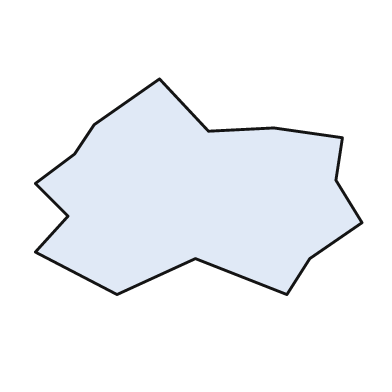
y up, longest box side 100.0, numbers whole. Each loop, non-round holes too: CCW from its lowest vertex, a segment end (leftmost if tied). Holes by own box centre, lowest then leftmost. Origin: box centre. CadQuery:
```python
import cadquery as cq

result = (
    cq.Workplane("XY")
    .moveTo(-25.0, -33.0)
    .lineTo(-1.0, -22.0)
    .lineTo(27.0, -33.0)
    .lineTo(34.0, -22.0)
    .lineTo(50.0, -11.0)
    .lineTo(42.0, 2.0)
    .lineTo(44.0, 15.0)
    .lineTo(23.0, 18.0)
    .lineTo(3.0, 17.0)
    .lineTo(-12.0, 33.0)
    .lineTo(-32.0, 19.0)
    .lineTo(-38.0, 10.0)
    .lineTo(-50.0, 1.0)
    .lineTo(-40.0, -9.0)
    .lineTo(-50.0, -20.0)
    .close()
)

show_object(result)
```